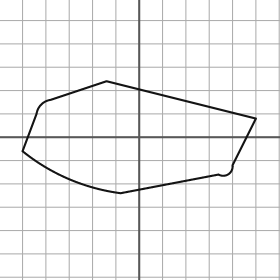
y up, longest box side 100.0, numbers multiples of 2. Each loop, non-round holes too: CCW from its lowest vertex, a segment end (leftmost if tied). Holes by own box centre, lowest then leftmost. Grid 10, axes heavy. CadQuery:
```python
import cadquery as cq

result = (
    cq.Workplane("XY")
    .moveTo(-8.0, -24.0)
    .lineTo(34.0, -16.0)
    .threePointArc((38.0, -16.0), (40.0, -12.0))
    .lineTo(50.0, 8.0)
    .lineTo(-14.0, 24.0)
    .lineTo(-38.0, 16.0)
    .threePointArc((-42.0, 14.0), (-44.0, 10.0))
    .lineTo(-50.0, -6.0)
    .threePointArc((-30.0, -18.0), (-8.0, -24.0))
    .close()
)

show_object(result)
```